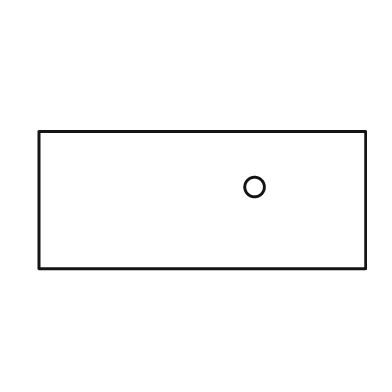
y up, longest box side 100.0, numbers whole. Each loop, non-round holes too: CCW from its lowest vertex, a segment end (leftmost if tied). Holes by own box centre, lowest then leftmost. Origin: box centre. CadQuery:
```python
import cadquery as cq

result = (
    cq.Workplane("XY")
    .moveTo(-50.0, -21.0)
    .lineTo(50.0, -21.0)
    .lineTo(50.0, 21.0)
    .lineTo(-50.0, 21.0)
    .close()
    .moveTo(16.0, 4.0)
    .circle(3.0)
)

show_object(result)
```